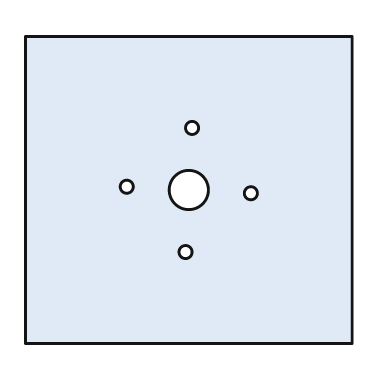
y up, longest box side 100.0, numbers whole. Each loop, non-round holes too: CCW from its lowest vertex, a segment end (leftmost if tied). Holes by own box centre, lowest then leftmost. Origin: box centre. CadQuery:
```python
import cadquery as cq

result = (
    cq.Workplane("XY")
    .moveTo(-50.0, -47.0)
    .lineTo(50.0, -47.0)
    .lineTo(50.0, 47.0)
    .lineTo(-50.0, 47.0)
    .close()
    .moveTo(-1.0, -19.0)
    .circle(2.0)
    .moveTo(19.0, -1.0)
    .circle(2.0)
    .moveTo(0.0, 0.0)
    .circle(6.0)
    .moveTo(-19.0, 1.0)
    .circle(2.0)
    .moveTo(1.0, 19.0)
    .circle(2.0)
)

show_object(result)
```